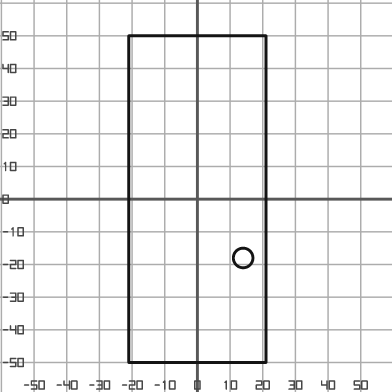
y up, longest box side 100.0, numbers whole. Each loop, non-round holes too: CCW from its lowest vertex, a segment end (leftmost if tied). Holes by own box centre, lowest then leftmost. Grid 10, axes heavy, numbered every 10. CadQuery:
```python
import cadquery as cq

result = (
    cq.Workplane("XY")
    .moveTo(-21.0, -50.0)
    .lineTo(21.0, -50.0)
    .lineTo(21.0, 50.0)
    .lineTo(-21.0, 50.0)
    .close()
    .moveTo(14.0, -18.0)
    .circle(3.0)
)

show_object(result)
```